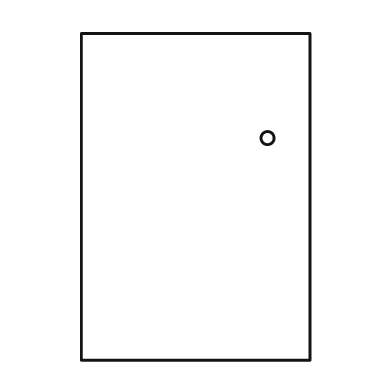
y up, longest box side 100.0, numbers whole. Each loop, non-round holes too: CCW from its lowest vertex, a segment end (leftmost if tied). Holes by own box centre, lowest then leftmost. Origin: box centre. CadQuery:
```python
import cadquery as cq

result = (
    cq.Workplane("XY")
    .moveTo(-35.0, -50.0)
    .lineTo(35.0, -50.0)
    .lineTo(35.0, 50.0)
    .lineTo(-35.0, 50.0)
    .close()
    .moveTo(22.0, 18.0)
    .circle(2.0)
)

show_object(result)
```